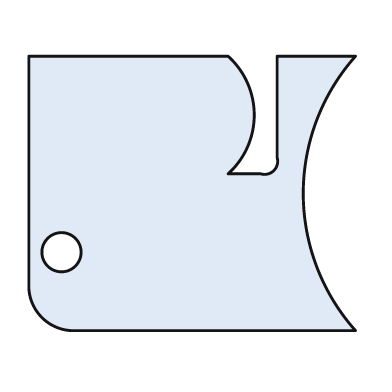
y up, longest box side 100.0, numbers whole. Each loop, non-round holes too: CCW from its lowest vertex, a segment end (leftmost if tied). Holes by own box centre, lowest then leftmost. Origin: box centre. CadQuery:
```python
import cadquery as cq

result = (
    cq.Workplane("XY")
    .moveTo(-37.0, -42.0)
    .lineTo(50.0, -42.0)
    .threePointArc((34.0, 0.0), (50.0, 42.0))
    .lineTo(26.0, 42.0)
    .lineTo(26.0, 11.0)
    .threePointArc((25.0, 7.0), (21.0, 6.0))
    .lineTo(11.0, 6.0)
    .threePointArc((19.0, 24.0), (11.0, 42.0))
    .lineTo(-50.0, 42.0)
    .lineTo(-50.0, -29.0)
    .threePointArc((-46.0, -38.0), (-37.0, -42.0))
    .close()
    .moveTo(-40.0, -18.0)
    .circle(6.0)
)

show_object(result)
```